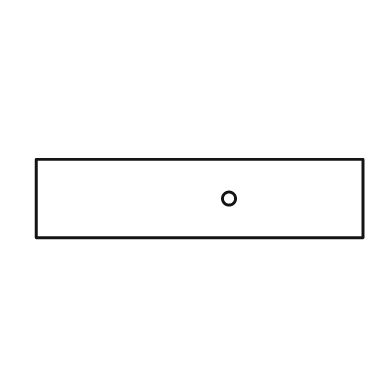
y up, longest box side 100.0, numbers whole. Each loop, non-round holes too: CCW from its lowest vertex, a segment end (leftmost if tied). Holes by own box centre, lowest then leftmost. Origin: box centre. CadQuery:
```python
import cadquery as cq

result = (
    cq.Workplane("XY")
    .moveTo(-50.0, -12.0)
    .lineTo(50.0, -12.0)
    .lineTo(50.0, 12.0)
    .lineTo(-50.0, 12.0)
    .close()
    .moveTo(9.0, 0.0)
    .circle(2.0)
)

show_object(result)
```